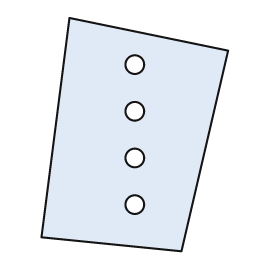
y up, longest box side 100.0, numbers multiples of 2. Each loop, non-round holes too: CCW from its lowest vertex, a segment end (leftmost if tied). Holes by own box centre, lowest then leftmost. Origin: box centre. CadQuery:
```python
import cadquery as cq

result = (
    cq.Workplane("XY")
    .moveTo(20.0, -50.0)
    .lineTo(40.0, 36.0)
    .lineTo(-28.0, 50.0)
    .lineTo(-40.0, -44.0)
    .close()
    .moveTo(0.0, -30.0)
    .circle(4.0)
    .moveTo(0.0, -10.0)
    .circle(4.0)
    .moveTo(0.0, 10.0)
    .circle(4.0)
    .moveTo(0.0, 30.0)
    .circle(4.0)
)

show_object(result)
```